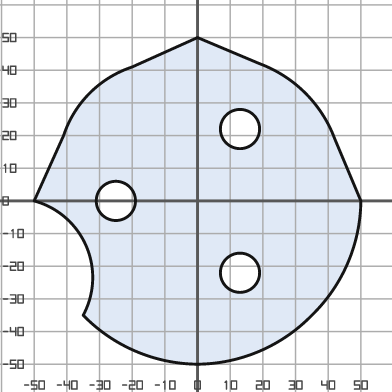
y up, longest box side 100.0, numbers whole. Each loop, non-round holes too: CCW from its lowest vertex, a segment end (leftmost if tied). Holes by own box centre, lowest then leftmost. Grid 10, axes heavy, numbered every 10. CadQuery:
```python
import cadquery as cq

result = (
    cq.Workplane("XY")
    .moveTo(0.0, -50.0)
    .threePointArc((19.0, -46.0), (35.0, -35.0))
    .threePointArc((46.0, -19.0), (50.0, 0.0))
    .lineTo(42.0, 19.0)
    .threePointArc((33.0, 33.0), (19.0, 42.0))
    .lineTo(0.0, 50.0)
    .lineTo(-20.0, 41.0)
    .threePointArc((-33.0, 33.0), (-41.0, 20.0))
    .lineTo(-50.0, 0.0)
    .threePointArc((-34.0, -14.0), (-35.0, -35.0))
    .threePointArc((-19.0, -46.0), (0.0, -50.0))
    .close()
    .moveTo(13.0, -22.0)
    .circle(6.0)
    .moveTo(-25.0, 0.0)
    .circle(6.0)
    .moveTo(13.0, 22.0)
    .circle(6.0)
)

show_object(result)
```